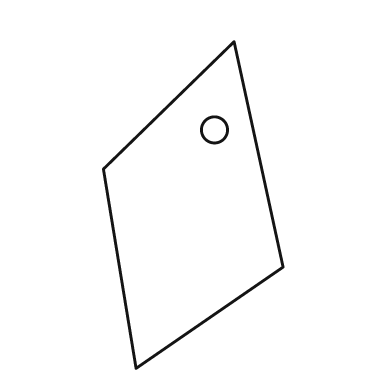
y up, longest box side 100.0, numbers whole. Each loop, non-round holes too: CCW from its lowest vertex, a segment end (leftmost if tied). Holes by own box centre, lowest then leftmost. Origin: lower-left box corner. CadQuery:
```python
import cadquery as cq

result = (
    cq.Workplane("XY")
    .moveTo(10.0, 0.0)
    .lineTo(55.0, 31.0)
    .lineTo(40.0, 100.0)
    .lineTo(0.0, 61.0)
    .close()
    .moveTo(34.0, 73.0)
    .circle(4.0)
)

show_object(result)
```